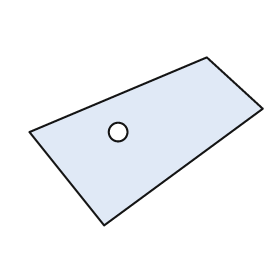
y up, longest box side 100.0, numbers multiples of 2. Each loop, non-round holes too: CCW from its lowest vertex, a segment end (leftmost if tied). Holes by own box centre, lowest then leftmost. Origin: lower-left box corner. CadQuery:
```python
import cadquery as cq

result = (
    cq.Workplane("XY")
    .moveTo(32.0, 0.0)
    .lineTo(100.0, 50.0)
    .lineTo(76.0, 72.0)
    .lineTo(0.0, 40.0)
    .close()
    .moveTo(38.0, 40.0)
    .circle(4.0)
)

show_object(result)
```